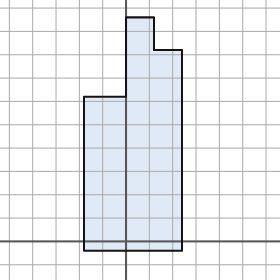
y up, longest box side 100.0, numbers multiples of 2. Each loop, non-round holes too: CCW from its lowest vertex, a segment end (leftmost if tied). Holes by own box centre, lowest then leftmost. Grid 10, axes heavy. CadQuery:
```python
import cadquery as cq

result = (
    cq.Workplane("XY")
    .moveTo(-18.0, -4.0)
    .lineTo(24.0, -4.0)
    .lineTo(24.0, 82.0)
    .lineTo(12.0, 82.0)
    .lineTo(12.0, 96.0)
    .lineTo(0.0, 96.0)
    .lineTo(0.0, 62.0)
    .lineTo(-18.0, 62.0)
    .close()
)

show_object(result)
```